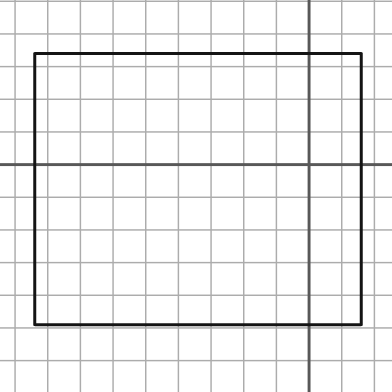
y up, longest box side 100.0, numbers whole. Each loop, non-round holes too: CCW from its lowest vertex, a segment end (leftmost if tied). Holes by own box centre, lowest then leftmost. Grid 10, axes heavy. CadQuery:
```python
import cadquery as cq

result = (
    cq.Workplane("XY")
    .moveTo(-84.0, -49.0)
    .lineTo(16.0, -49.0)
    .lineTo(16.0, 34.0)
    .lineTo(-84.0, 34.0)
    .close()
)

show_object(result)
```